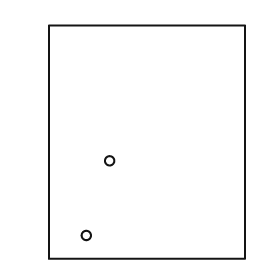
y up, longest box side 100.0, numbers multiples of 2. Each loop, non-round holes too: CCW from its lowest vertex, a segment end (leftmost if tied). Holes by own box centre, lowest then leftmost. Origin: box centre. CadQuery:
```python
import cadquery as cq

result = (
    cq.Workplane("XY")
    .moveTo(-42.0, -50.0)
    .lineTo(42.0, -50.0)
    .lineTo(42.0, 50.0)
    .lineTo(-42.0, 50.0)
    .close()
    .moveTo(-26.0, -40.0)
    .circle(2.0)
    .moveTo(-16.0, -8.0)
    .circle(2.0)
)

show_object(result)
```